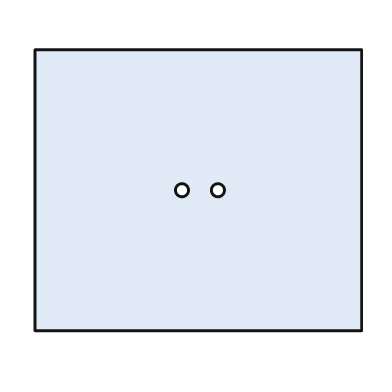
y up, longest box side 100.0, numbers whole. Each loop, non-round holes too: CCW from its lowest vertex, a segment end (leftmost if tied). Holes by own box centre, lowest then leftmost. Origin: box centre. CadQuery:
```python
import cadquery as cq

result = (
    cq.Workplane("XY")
    .moveTo(-50.0, -43.0)
    .lineTo(50.0, -43.0)
    .lineTo(50.0, 43.0)
    .lineTo(-50.0, 43.0)
    .close()
    .moveTo(-5.0, 0.0)
    .circle(2.0)
    .moveTo(6.0, 0.0)
    .circle(2.0)
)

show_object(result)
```